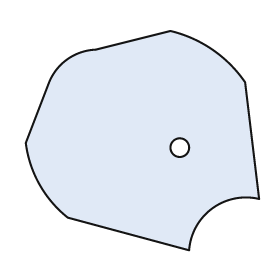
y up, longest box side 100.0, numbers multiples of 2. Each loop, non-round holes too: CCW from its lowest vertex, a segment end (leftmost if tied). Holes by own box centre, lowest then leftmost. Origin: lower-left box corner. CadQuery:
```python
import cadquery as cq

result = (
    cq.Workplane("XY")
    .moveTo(70.0, 0.0)
    .threePointArc((80.0, 18.0), (100.0, 22.0))
    .lineTo(94.0, 72.0)
    .threePointArc((80.0, 86.0), (62.0, 94.0))
    .lineTo(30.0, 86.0)
    .threePointArc((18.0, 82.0), (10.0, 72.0))
    .lineTo(0.0, 46.0)
    .threePointArc((6.0, 28.0), (18.0, 14.0))
    .close()
    .moveTo(66.0, 44.0)
    .circle(4.0)
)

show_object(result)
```